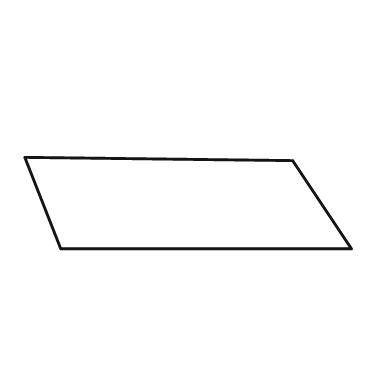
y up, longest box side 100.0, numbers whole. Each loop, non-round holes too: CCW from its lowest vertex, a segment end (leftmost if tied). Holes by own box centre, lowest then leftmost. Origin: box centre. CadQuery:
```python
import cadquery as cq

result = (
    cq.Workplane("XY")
    .moveTo(-39.0, -14.0)
    .lineTo(50.0, -14.0)
    .lineTo(32.0, 13.0)
    .lineTo(-50.0, 14.0)
    .close()
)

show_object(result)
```